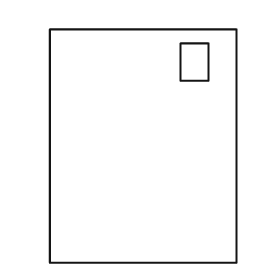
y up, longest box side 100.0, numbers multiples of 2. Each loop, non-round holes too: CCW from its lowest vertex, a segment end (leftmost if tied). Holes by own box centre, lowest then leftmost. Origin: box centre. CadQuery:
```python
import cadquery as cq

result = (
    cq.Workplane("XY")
    .moveTo(-40.0, -50.0)
    .lineTo(40.0, -50.0)
    .lineTo(40.0, 50.0)
    .lineTo(-40.0, 50.0)
    .close()
    .moveTo(16.0, 28.0)
    .lineTo(28.0, 28.0)
    .lineTo(28.0, 44.0)
    .lineTo(16.0, 44.0)
    .close()
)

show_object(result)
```